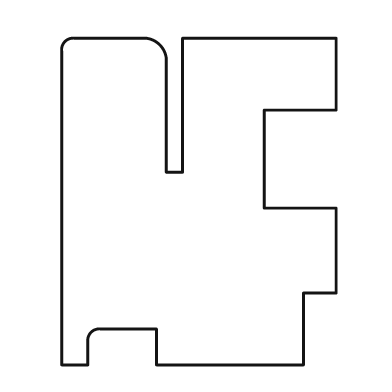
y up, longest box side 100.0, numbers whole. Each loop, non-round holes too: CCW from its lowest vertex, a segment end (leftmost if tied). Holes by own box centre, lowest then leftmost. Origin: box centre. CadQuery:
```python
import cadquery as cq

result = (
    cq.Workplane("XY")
    .moveTo(-42.0, -50.0)
    .lineTo(-34.0, -50.0)
    .lineTo(-34.0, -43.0)
    .threePointArc((-33.0, -40.0), (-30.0, -39.0))
    .lineTo(-13.0, -39.0)
    .lineTo(-13.0, -50.0)
    .lineTo(32.0, -50.0)
    .lineTo(32.0, -28.0)
    .lineTo(42.0, -28.0)
    .lineTo(42.0, -2.0)
    .lineTo(20.0, -2.0)
    .lineTo(20.0, 28.0)
    .lineTo(42.0, 28.0)
    .lineTo(42.0, 50.0)
    .lineTo(-5.0, 50.0)
    .lineTo(-5.0, 9.0)
    .lineTo(-10.0, 9.0)
    .lineTo(-10.0, 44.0)
    .threePointArc((-12.0, 48.0), (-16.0, 50.0))
    .lineTo(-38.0, 50.0)
    .threePointArc((-41.0, 49.0), (-42.0, 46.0))
    .close()
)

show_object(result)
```